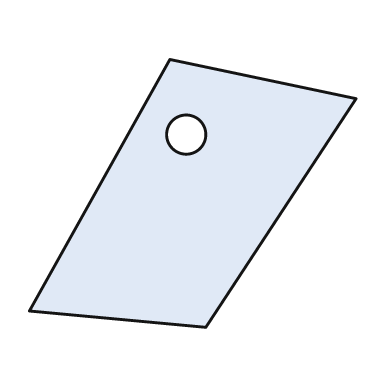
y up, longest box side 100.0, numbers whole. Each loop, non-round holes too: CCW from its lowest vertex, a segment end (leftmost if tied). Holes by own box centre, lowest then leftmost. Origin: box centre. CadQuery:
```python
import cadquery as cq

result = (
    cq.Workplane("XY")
    .moveTo(4.0, -41.0)
    .lineTo(50.0, 29.0)
    .lineTo(-7.0, 41.0)
    .lineTo(-50.0, -36.0)
    .close()
    .moveTo(-2.0, 18.0)
    .circle(6.0)
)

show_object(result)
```